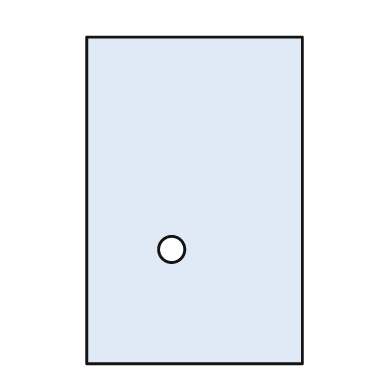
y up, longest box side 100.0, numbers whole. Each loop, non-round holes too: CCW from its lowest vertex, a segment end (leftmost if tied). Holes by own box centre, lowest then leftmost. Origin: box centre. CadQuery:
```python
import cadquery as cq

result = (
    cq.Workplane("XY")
    .moveTo(-33.0, -50.0)
    .lineTo(33.0, -50.0)
    .lineTo(33.0, 50.0)
    .lineTo(-33.0, 50.0)
    .close()
    .moveTo(-7.0, -15.0)
    .circle(4.0)
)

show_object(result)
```